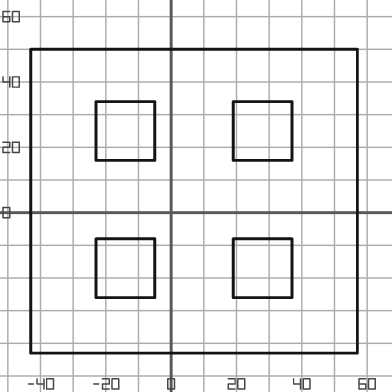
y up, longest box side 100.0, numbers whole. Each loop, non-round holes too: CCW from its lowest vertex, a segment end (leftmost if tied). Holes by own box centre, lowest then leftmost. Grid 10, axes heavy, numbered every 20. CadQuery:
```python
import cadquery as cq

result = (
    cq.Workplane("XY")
    .moveTo(-43.0, -43.0)
    .lineTo(57.0, -43.0)
    .lineTo(57.0, 50.0)
    .lineTo(-43.0, 50.0)
    .close()
    .moveTo(-23.0, -26.0)
    .lineTo(-5.0, -26.0)
    .lineTo(-5.0, -8.0)
    .lineTo(-23.0, -8.0)
    .close()
    .moveTo(19.0, -26.0)
    .lineTo(37.0, -26.0)
    .lineTo(37.0, -8.0)
    .lineTo(19.0, -8.0)
    .close()
    .moveTo(-23.0, 16.0)
    .lineTo(-5.0, 16.0)
    .lineTo(-5.0, 34.0)
    .lineTo(-23.0, 34.0)
    .close()
    .moveTo(19.0, 16.0)
    .lineTo(37.0, 16.0)
    .lineTo(37.0, 34.0)
    .lineTo(19.0, 34.0)
    .close()
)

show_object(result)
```